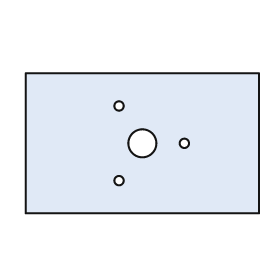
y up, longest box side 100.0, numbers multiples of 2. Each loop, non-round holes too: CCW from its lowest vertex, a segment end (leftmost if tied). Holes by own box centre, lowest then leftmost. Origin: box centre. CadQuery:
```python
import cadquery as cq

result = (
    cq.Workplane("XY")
    .moveTo(-50.0, -30.0)
    .lineTo(50.0, -30.0)
    .lineTo(50.0, 30.0)
    .lineTo(-50.0, 30.0)
    .close()
    .moveTo(-10.0, -16.0)
    .circle(2.0)
    .moveTo(0.0, 0.0)
    .circle(6.0)
    .moveTo(18.0, 0.0)
    .circle(2.0)
    .moveTo(-10.0, 16.0)
    .circle(2.0)
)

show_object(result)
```